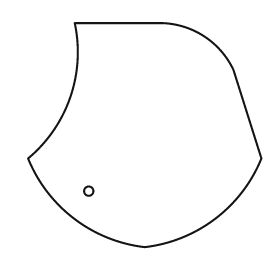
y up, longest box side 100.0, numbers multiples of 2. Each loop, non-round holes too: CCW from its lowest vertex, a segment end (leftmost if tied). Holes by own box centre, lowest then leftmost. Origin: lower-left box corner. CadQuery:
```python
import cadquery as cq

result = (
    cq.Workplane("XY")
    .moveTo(50.0, 0.0)
    .threePointArc((80.0, 12.0), (100.0, 38.0))
    .lineTo(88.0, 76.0)
    .threePointArc((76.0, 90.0), (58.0, 96.0))
    .lineTo(20.0, 96.0)
    .threePointArc((18.0, 64.0), (0.0, 38.0))
    .threePointArc((20.0, 12.0), (50.0, 0.0))
    .close()
    .moveTo(26.0, 24.0)
    .circle(2.0)
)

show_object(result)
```